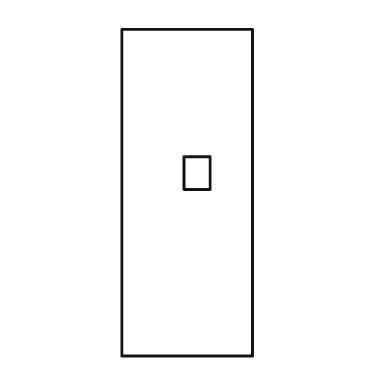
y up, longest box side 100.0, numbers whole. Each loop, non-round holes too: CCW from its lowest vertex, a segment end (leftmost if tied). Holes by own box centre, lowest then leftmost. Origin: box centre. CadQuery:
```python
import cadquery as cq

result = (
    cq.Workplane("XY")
    .moveTo(-20.0, -50.0)
    .lineTo(20.0, -50.0)
    .lineTo(20.0, 50.0)
    .lineTo(-20.0, 50.0)
    .close()
    .moveTo(-1.0, 1.0)
    .lineTo(7.0, 1.0)
    .lineTo(7.0, 11.0)
    .lineTo(-1.0, 11.0)
    .close()
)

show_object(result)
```